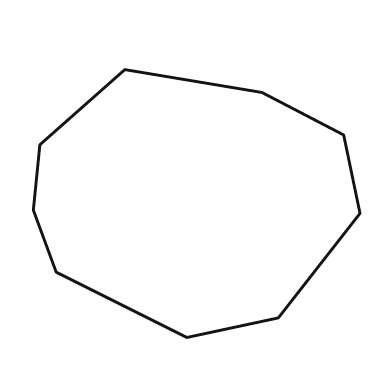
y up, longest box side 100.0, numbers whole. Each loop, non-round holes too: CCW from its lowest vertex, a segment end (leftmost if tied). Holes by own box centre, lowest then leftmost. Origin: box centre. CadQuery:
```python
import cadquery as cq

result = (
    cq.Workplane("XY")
    .moveTo(-3.0, -41.0)
    .lineTo(25.0, -35.0)
    .lineTo(50.0, -3.0)
    .lineTo(45.0, 21.0)
    .lineTo(20.0, 34.0)
    .lineTo(-22.0, 41.0)
    .lineTo(-48.0, 18.0)
    .lineTo(-50.0, -2.0)
    .lineTo(-43.0, -21.0)
    .close()
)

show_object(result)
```